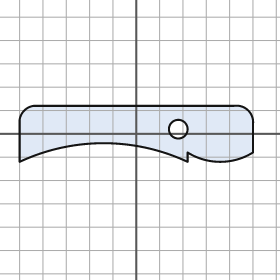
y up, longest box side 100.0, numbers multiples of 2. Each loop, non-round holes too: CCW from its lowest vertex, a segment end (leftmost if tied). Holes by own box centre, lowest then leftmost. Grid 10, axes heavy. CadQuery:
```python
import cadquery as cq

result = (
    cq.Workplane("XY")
    .moveTo(-50.0, -12.0)
    .threePointArc((-14.0, -4.0), (22.0, -12.0))
    .lineTo(22.0, -8.0)
    .threePointArc((36.0, -12.0), (50.0, -8.0))
    .lineTo(50.0, 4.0)
    .threePointArc((48.0, 10.0), (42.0, 12.0))
    .lineTo(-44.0, 12.0)
    .threePointArc((-48.0, 10.0), (-50.0, 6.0))
    .close()
    .moveTo(18.0, 2.0)
    .circle(4.0)
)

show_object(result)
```